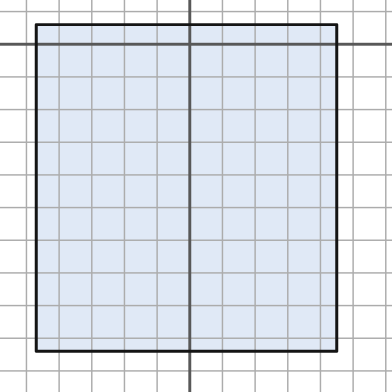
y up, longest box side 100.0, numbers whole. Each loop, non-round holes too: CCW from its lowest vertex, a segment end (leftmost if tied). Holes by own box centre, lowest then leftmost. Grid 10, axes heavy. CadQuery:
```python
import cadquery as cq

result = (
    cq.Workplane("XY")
    .moveTo(-47.0, -94.0)
    .lineTo(45.0, -94.0)
    .lineTo(45.0, 6.0)
    .lineTo(-47.0, 6.0)
    .close()
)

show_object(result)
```